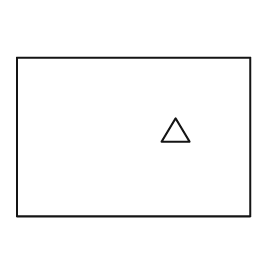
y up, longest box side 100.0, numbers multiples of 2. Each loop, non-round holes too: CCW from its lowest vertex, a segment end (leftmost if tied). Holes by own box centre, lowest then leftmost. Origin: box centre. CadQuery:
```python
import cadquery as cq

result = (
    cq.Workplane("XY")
    .moveTo(-50.0, -34.0)
    .lineTo(50.0, -34.0)
    .lineTo(50.0, 34.0)
    .lineTo(-50.0, 34.0)
    .close()
    .moveTo(12.0, -2.0)
    .lineTo(24.0, -2.0)
    .lineTo(18.0, 8.0)
    .close()
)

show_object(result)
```